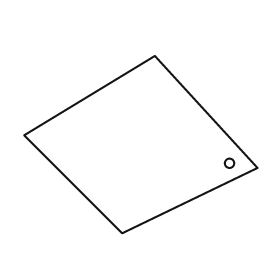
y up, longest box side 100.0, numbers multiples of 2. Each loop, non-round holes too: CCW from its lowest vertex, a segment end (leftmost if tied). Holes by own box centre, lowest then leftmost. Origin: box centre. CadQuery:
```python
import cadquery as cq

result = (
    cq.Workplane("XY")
    .moveTo(-8.0, -38.0)
    .lineTo(50.0, -10.0)
    .lineTo(6.0, 38.0)
    .lineTo(-50.0, 4.0)
    .close()
    .moveTo(38.0, -8.0)
    .circle(2.0)
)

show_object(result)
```